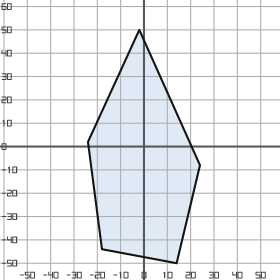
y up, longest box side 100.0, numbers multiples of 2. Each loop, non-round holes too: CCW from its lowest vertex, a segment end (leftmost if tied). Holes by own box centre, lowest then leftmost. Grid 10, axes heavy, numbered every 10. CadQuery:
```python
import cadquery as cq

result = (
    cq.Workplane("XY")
    .moveTo(14.0, -50.0)
    .lineTo(24.0, -8.0)
    .lineTo(-2.0, 50.0)
    .lineTo(-24.0, 2.0)
    .lineTo(-18.0, -44.0)
    .close()
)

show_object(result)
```